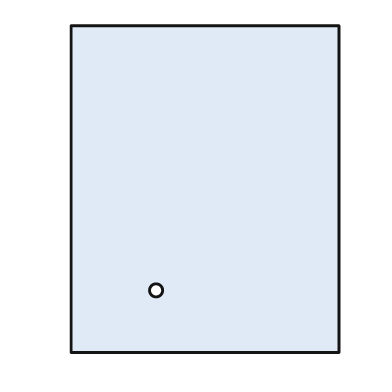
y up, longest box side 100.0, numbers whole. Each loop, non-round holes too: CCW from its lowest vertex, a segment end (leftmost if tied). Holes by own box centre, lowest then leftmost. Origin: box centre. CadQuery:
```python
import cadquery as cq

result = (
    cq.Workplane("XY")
    .moveTo(-41.0, -50.0)
    .lineTo(41.0, -50.0)
    .lineTo(41.0, 50.0)
    .lineTo(-41.0, 50.0)
    .close()
    .moveTo(-15.0, -31.0)
    .circle(2.0)
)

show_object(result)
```